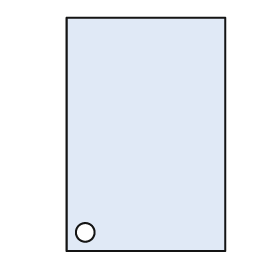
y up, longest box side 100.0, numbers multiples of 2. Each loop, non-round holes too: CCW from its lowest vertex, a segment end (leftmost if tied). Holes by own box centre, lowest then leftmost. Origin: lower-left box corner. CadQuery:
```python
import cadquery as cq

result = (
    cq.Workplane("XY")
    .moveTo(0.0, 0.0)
    .lineTo(68.0, 0.0)
    .lineTo(68.0, 100.0)
    .lineTo(0.0, 100.0)
    .close()
    .moveTo(8.0, 8.0)
    .circle(4.0)
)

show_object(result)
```